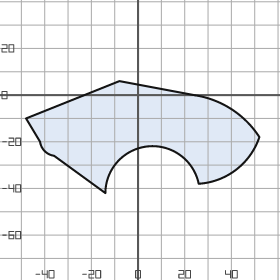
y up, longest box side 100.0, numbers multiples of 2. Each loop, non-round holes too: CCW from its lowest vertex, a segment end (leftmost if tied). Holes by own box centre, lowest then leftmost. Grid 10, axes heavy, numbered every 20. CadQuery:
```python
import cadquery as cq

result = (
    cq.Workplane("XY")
    .moveTo(-14.0, -42.0)
    .threePointArc((4.0, -22.0), (26.0, -38.0))
    .threePointArc((42.0, -32.0), (52.0, -18.0))
    .threePointArc((40.0, -6.0), (24.0, 0.0))
    .lineTo(-8.0, 6.0)
    .lineTo(-48.0, -10.0)
    .lineTo(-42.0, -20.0)
    .threePointArc((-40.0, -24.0), (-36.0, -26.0))
    .close()
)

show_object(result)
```